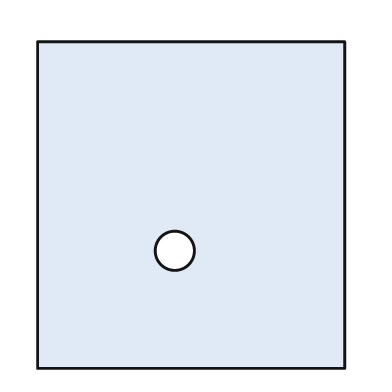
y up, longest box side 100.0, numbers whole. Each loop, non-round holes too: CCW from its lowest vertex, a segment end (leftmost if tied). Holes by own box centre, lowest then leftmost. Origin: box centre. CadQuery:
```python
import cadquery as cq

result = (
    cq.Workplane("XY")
    .moveTo(-47.0, -50.0)
    .lineTo(47.0, -50.0)
    .lineTo(47.0, 50.0)
    .lineTo(-47.0, 50.0)
    .close()
    .moveTo(-5.0, -14.0)
    .circle(6.0)
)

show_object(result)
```